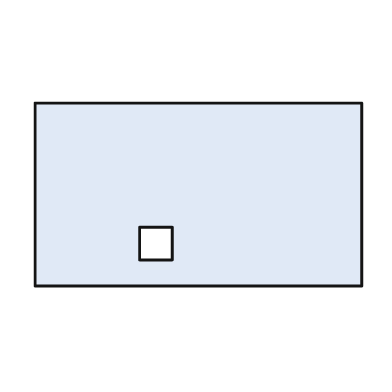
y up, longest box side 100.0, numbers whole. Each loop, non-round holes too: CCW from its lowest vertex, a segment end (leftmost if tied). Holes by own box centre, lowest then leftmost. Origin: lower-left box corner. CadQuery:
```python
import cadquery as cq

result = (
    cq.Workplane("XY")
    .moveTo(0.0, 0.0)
    .lineTo(100.0, 0.0)
    .lineTo(100.0, 56.0)
    .lineTo(0.0, 56.0)
    .close()
    .moveTo(32.0, 8.0)
    .lineTo(42.0, 8.0)
    .lineTo(42.0, 18.0)
    .lineTo(32.0, 18.0)
    .close()
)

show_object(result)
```